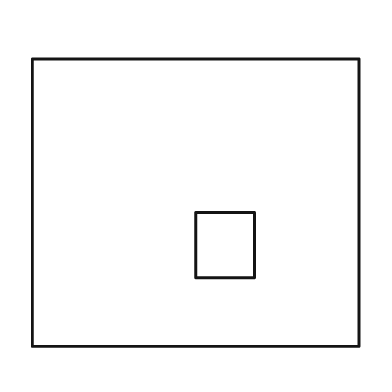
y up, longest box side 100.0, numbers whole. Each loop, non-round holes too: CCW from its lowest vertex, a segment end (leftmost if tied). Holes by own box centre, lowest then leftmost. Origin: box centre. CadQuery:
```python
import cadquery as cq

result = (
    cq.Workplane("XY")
    .moveTo(-50.0, -44.0)
    .lineTo(50.0, -44.0)
    .lineTo(50.0, 44.0)
    .lineTo(-50.0, 44.0)
    .close()
    .moveTo(0.0, -23.0)
    .lineTo(18.0, -23.0)
    .lineTo(18.0, -3.0)
    .lineTo(0.0, -3.0)
    .close()
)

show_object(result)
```